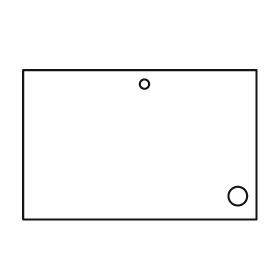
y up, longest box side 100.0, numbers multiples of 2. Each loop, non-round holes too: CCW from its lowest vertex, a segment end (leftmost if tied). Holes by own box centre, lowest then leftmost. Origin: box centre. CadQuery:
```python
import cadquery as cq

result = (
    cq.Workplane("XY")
    .moveTo(-50.0, -32.0)
    .lineTo(50.0, -32.0)
    .lineTo(50.0, 32.0)
    .lineTo(-50.0, 32.0)
    .close()
    .moveTo(42.0, -22.0)
    .circle(4.0)
    .moveTo(2.0, 26.0)
    .circle(2.0)
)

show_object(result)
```